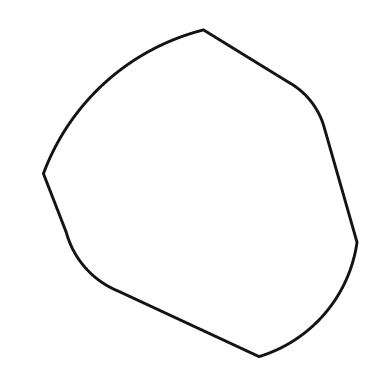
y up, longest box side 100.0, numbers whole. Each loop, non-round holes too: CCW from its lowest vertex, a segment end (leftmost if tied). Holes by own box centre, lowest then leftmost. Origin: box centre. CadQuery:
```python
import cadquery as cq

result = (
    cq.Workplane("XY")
    .moveTo(18.0, -50.0)
    .threePointArc((38.0, -37.0), (48.0, -15.0))
    .lineTo(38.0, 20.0)
    .threePointArc((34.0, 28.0), (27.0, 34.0))
    .lineTo(1.0, 50.0)
    .threePointArc((-29.0, 34.0), (-48.0, 6.0))
    .lineTo(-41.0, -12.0)
    .threePointArc((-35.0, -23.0), (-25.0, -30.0))
    .close()
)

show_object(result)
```